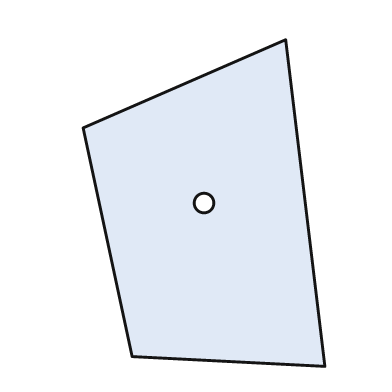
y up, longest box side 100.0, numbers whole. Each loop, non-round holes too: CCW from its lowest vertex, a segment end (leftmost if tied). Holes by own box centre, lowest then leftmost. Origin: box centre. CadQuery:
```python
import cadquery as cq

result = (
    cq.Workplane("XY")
    .moveTo(37.0, -50.0)
    .lineTo(25.0, 50.0)
    .lineTo(-37.0, 23.0)
    .lineTo(-22.0, -47.0)
    .close()
    .moveTo(0.0, 0.0)
    .circle(3.0)
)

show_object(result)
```